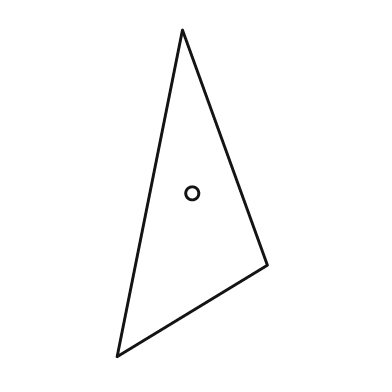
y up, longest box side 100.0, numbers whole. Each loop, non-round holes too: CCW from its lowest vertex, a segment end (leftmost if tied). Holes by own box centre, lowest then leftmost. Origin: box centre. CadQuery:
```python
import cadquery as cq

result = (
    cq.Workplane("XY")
    .moveTo(-23.0, -50.0)
    .lineTo(23.0, -22.0)
    .lineTo(-3.0, 50.0)
    .close()
    .moveTo(0.0, 0.0)
    .circle(2.0)
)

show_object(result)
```